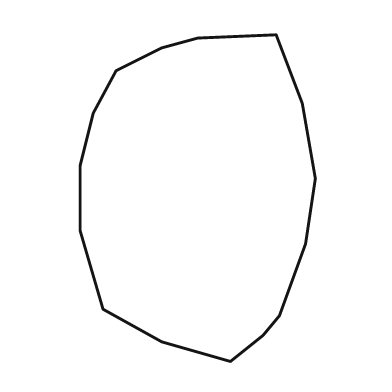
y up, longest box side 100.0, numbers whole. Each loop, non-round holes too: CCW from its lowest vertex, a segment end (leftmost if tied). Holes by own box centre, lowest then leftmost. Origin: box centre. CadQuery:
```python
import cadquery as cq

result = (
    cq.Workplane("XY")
    .moveTo(10.0, -50.0)
    .lineTo(20.0, -42.0)
    .lineTo(25.0, -36.0)
    .lineTo(33.0, -14.0)
    .lineTo(36.0, 6.0)
    .lineTo(32.0, 29.0)
    .lineTo(24.0, 50.0)
    .lineTo(0.0, 49.0)
    .lineTo(-11.0, 46.0)
    .lineTo(-25.0, 39.0)
    .lineTo(-32.0, 26.0)
    .lineTo(-36.0, 10.0)
    .lineTo(-36.0, -10.0)
    .lineTo(-29.0, -34.0)
    .lineTo(-11.0, -44.0)
    .close()
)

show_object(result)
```